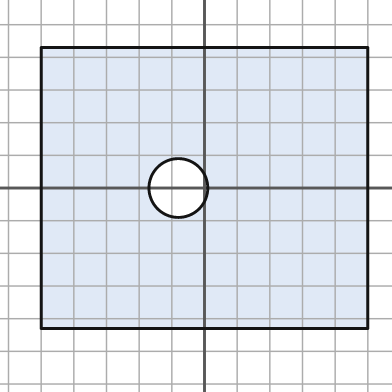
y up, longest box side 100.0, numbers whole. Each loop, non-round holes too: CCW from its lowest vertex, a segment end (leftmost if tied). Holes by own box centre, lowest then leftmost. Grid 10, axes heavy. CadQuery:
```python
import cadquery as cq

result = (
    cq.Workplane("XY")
    .moveTo(-50.0, -43.0)
    .lineTo(50.0, -43.0)
    .lineTo(50.0, 43.0)
    .lineTo(-50.0, 43.0)
    .close()
    .moveTo(-8.0, 0.0)
    .circle(9.0)
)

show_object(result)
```